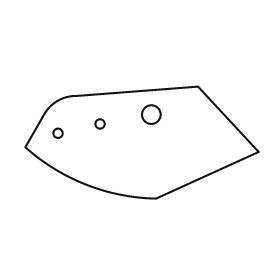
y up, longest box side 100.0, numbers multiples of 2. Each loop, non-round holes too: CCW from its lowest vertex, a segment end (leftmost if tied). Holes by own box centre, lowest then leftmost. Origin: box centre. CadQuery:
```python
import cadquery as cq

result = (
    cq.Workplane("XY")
    .moveTo(6.0, -24.0)
    .lineTo(50.0, -4.0)
    .lineTo(24.0, 24.0)
    .lineTo(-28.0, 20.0)
    .threePointArc((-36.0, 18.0), (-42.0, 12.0))
    .lineTo(-50.0, -2.0)
    .threePointArc((-24.0, -18.0), (6.0, -24.0))
    .close()
    .moveTo(-36.0, 4.0)
    .circle(2.0)
    .moveTo(-18.0, 8.0)
    .circle(2.0)
    .moveTo(4.0, 12.0)
    .circle(4.0)
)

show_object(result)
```